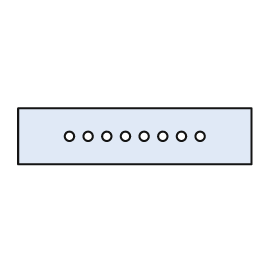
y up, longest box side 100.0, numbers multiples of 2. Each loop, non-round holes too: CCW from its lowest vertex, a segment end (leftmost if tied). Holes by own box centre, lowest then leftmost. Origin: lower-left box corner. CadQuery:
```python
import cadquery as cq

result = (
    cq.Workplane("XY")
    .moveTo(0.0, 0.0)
    .lineTo(100.0, 0.0)
    .lineTo(100.0, 24.0)
    .lineTo(0.0, 24.0)
    .close()
    .moveTo(22.0, 12.0)
    .circle(2.0)
    .moveTo(30.0, 12.0)
    .circle(2.0)
    .moveTo(38.0, 12.0)
    .circle(2.0)
    .moveTo(46.0, 12.0)
    .circle(2.0)
    .moveTo(54.0, 12.0)
    .circle(2.0)
    .moveTo(62.0, 12.0)
    .circle(2.0)
    .moveTo(70.0, 12.0)
    .circle(2.0)
    .moveTo(78.0, 12.0)
    .circle(2.0)
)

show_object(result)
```